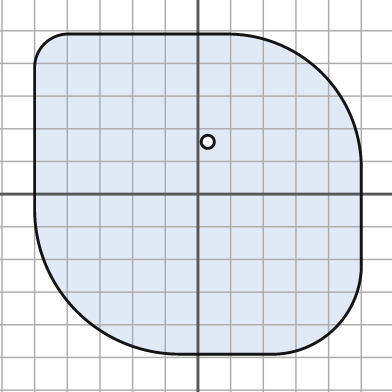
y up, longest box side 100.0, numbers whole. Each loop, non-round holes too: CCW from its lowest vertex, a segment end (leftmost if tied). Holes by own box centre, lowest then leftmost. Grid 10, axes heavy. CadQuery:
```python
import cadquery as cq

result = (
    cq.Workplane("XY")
    .moveTo(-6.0, -49.0)
    .lineTo(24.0, -49.0)
    .threePointArc((42.0, -41.0), (50.0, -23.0))
    .lineTo(50.0, 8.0)
    .threePointArc((38.0, 37.0), (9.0, 49.0))
    .lineTo(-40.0, 49.0)
    .threePointArc((-47.0, 46.0), (-50.0, 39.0))
    .lineTo(-50.0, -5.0)
    .threePointArc((-37.0, -36.0), (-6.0, -49.0))
    .close()
    .moveTo(3.0, 16.0)
    .circle(2.0)
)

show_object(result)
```